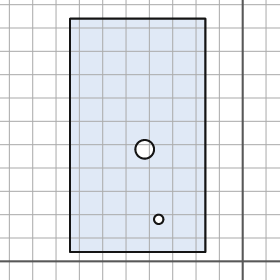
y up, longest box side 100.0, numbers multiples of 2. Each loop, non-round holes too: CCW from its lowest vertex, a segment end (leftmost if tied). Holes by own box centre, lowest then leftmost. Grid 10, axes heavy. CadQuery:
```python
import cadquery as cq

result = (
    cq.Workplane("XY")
    .moveTo(-74.0, 4.0)
    .lineTo(-16.0, 4.0)
    .lineTo(-16.0, 104.0)
    .lineTo(-74.0, 104.0)
    .close()
    .moveTo(-36.0, 18.0)
    .circle(2.0)
    .moveTo(-42.0, 48.0)
    .circle(4.0)
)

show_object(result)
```